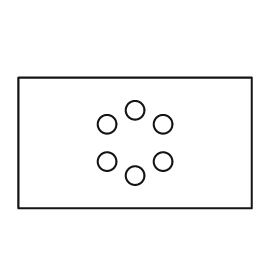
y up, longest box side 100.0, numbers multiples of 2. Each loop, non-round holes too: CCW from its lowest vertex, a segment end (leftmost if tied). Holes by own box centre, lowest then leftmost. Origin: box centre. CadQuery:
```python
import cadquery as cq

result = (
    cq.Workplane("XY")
    .moveTo(-50.0, -28.0)
    .lineTo(50.0, -28.0)
    .lineTo(50.0, 28.0)
    .lineTo(-50.0, 28.0)
    .close()
    .moveTo(0.0, -14.0)
    .circle(4.0)
    .moveTo(-12.0, -8.0)
    .circle(4.0)
    .moveTo(12.0, -8.0)
    .circle(4.0)
    .moveTo(-12.0, 8.0)
    .circle(4.0)
    .moveTo(12.0, 8.0)
    .circle(4.0)
    .moveTo(0.0, 14.0)
    .circle(4.0)
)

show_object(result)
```